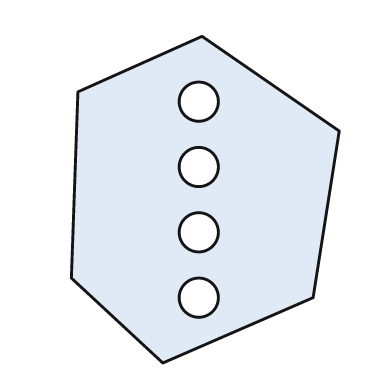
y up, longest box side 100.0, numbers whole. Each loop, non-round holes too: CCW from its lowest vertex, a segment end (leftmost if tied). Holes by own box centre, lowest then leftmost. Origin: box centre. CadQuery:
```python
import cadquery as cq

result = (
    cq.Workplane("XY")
    .moveTo(-13.0, -50.0)
    .lineTo(33.0, -30.0)
    .lineTo(41.0, 21.0)
    .lineTo(-1.0, 50.0)
    .lineTo(-39.0, 33.0)
    .lineTo(-41.0, -24.0)
    .close()
    .moveTo(-2.0, -30.0)
    .circle(6.0)
    .moveTo(-2.0, -10.0)
    .circle(6.0)
    .moveTo(-2.0, 10.0)
    .circle(6.0)
    .moveTo(-2.0, 30.0)
    .circle(6.0)
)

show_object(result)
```